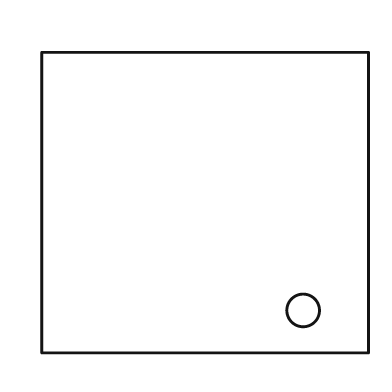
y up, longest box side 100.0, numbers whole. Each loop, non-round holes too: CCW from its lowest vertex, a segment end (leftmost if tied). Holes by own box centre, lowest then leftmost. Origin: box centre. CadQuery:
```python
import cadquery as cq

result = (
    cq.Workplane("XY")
    .moveTo(-50.0, -46.0)
    .lineTo(50.0, -46.0)
    .lineTo(50.0, 46.0)
    .lineTo(-50.0, 46.0)
    .close()
    .moveTo(30.0, -33.0)
    .circle(5.0)
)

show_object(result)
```